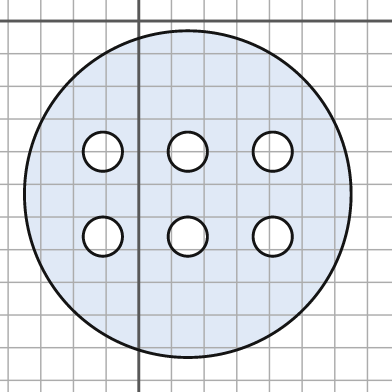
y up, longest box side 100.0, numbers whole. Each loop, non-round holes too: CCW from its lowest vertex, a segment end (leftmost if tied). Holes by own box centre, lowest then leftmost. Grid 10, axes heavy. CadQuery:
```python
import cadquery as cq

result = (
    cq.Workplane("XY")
    .moveTo(15.0, -53.0)
    .circle(50.0)
    .moveTo(-11.0, -66.0)
    .circle(6.0)
    .moveTo(15.0, -66.0)
    .circle(6.0)
    .moveTo(41.0, -66.0)
    .circle(6.0)
    .moveTo(-11.0, -40.0)
    .circle(6.0)
    .moveTo(15.0, -40.0)
    .circle(6.0)
    .moveTo(41.0, -40.0)
    .circle(6.0)
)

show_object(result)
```